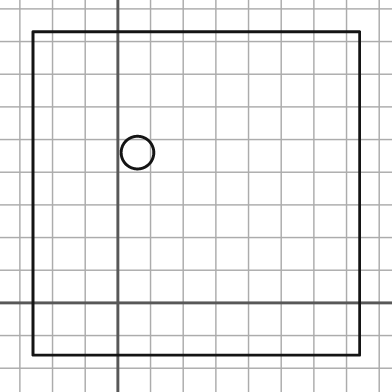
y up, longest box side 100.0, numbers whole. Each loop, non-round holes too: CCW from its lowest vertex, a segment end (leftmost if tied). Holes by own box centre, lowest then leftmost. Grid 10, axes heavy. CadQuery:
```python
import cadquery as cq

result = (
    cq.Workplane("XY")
    .moveTo(-26.0, -16.0)
    .lineTo(74.0, -16.0)
    .lineTo(74.0, 83.0)
    .lineTo(-26.0, 83.0)
    .close()
    .moveTo(6.0, 46.0)
    .circle(5.0)
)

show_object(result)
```